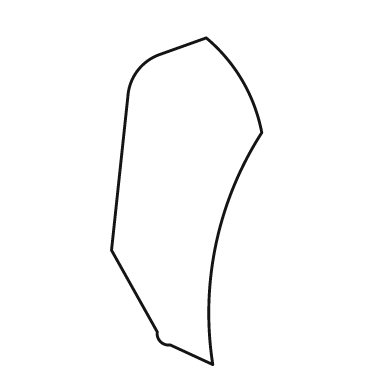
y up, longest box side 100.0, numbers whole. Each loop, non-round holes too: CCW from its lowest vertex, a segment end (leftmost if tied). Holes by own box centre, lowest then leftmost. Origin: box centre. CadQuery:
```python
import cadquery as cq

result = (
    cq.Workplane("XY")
    .moveTo(8.0, -50.0)
    .threePointArc((9.0, -13.0), (23.0, 21.0))
    .threePointArc((17.0, 37.0), (6.0, 50.0))
    .lineTo(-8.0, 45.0)
    .threePointArc((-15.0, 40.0), (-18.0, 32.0))
    .lineTo(-23.0, -15.0)
    .lineTo(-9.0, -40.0)
    .threePointArc((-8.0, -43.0), (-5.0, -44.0))
    .close()
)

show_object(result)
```